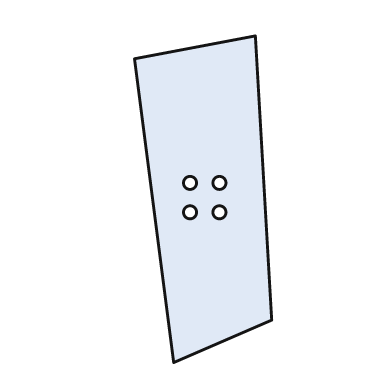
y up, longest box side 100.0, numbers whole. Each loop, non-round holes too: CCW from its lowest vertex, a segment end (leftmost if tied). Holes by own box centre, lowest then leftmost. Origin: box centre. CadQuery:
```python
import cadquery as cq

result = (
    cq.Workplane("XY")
    .moveTo(-9.0, -50.0)
    .lineTo(21.0, -37.0)
    .lineTo(16.0, 50.0)
    .lineTo(-21.0, 43.0)
    .close()
    .moveTo(-4.0, -4.0)
    .circle(2.0)
    .moveTo(5.0, -4.0)
    .circle(2.0)
    .moveTo(-4.0, 5.0)
    .circle(2.0)
    .moveTo(5.0, 5.0)
    .circle(2.0)
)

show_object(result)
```